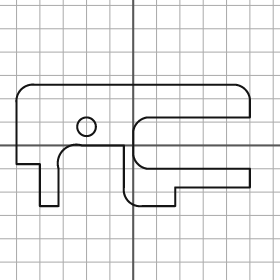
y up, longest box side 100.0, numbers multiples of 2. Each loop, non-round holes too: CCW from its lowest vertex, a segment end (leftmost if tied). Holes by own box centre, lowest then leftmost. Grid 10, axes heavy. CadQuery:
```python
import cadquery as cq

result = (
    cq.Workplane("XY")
    .moveTo(-40.0, -26.0)
    .lineTo(-32.0, -26.0)
    .lineTo(-32.0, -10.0)
    .threePointArc((-30.0, -2.0), (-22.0, 0.0))
    .lineTo(-4.0, 0.0)
    .lineTo(-4.0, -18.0)
    .threePointArc((-2.0, -24.0), (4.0, -26.0))
    .lineTo(18.0, -26.0)
    .lineTo(18.0, -18.0)
    .lineTo(50.0, -18.0)
    .lineTo(50.0, -10.0)
    .lineTo(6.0, -10.0)
    .threePointArc((2.0, -8.0), (0.0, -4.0))
    .lineTo(0.0, 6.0)
    .threePointArc((2.0, 10.0), (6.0, 12.0))
    .lineTo(50.0, 12.0)
    .lineTo(50.0, 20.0)
    .threePointArc((48.0, 24.0), (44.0, 26.0))
    .lineTo(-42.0, 26.0)
    .threePointArc((-48.0, 24.0), (-50.0, 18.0))
    .lineTo(-50.0, -8.0)
    .lineTo(-40.0, -8.0)
    .close()
    .moveTo(-20.0, 8.0)
    .circle(4.0)
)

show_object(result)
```